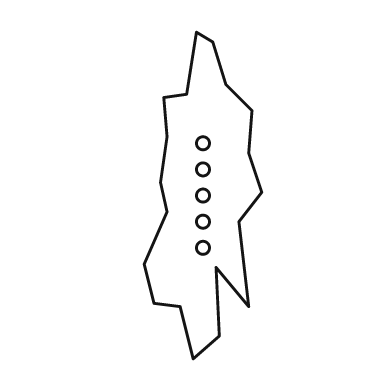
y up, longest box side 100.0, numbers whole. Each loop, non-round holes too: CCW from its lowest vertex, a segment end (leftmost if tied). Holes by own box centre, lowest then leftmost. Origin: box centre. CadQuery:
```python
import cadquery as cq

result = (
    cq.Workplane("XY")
    .moveTo(-3.0, -50.0)
    .lineTo(5.0, -43.0)
    .lineTo(4.0, -22.0)
    .lineTo(14.0, -34.0)
    .lineTo(11.0, -8.0)
    .lineTo(18.0, 1.0)
    .lineTo(14.0, 13.0)
    .lineTo(15.0, 26.0)
    .lineTo(7.0, 34.0)
    .lineTo(3.0, 47.0)
    .lineTo(-2.0, 50.0)
    .lineTo(-5.0, 31.0)
    .lineTo(-12.0, 30.0)
    .lineTo(-11.0, 18.0)
    .lineTo(-13.0, 4.0)
    .lineTo(-11.0, -5.0)
    .lineTo(-18.0, -21.0)
    .lineTo(-15.0, -33.0)
    .lineTo(-7.0, -34.0)
    .close()
    .moveTo(0.0, -16.0)
    .circle(2.0)
    .moveTo(0.0, -8.0)
    .circle(2.0)
    .moveTo(0.0, 0.0)
    .circle(2.0)
    .moveTo(0.0, 8.0)
    .circle(2.0)
    .moveTo(0.0, 16.0)
    .circle(2.0)
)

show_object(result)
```